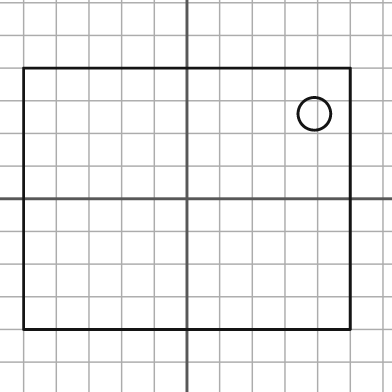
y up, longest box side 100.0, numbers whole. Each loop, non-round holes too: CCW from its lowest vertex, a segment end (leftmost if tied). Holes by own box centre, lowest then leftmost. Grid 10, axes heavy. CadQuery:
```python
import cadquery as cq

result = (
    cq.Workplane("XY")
    .moveTo(-50.0, -40.0)
    .lineTo(50.0, -40.0)
    .lineTo(50.0, 40.0)
    .lineTo(-50.0, 40.0)
    .close()
    .moveTo(39.0, 26.0)
    .circle(5.0)
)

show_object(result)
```